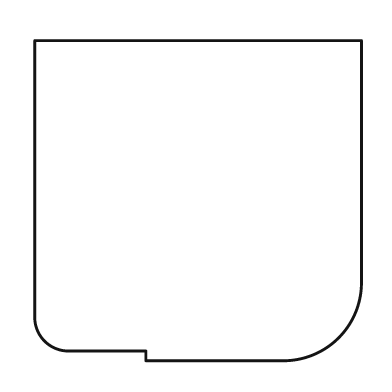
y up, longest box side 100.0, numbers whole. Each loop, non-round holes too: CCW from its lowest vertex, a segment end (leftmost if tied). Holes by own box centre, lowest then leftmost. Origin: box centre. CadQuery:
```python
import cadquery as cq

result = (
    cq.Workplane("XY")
    .moveTo(-16.0, -49.0)
    .lineTo(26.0, -49.0)
    .threePointArc((43.0, -42.0), (50.0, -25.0))
    .lineTo(50.0, 49.0)
    .lineTo(-50.0, 49.0)
    .lineTo(-50.0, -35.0)
    .threePointArc((-47.0, -43.0), (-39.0, -46.0))
    .lineTo(-16.0, -46.0)
    .close()
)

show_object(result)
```